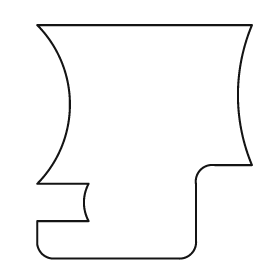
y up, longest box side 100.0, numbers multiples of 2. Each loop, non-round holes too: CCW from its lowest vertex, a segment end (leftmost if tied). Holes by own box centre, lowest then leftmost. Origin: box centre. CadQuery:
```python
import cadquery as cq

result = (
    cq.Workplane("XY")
    .moveTo(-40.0, -50.0)
    .lineTo(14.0, -50.0)
    .threePointArc((20.0, -48.0), (22.0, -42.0))
    .lineTo(22.0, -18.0)
    .threePointArc((24.0, -12.0), (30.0, -10.0))
    .lineTo(46.0, -10.0)
    .threePointArc((40.0, 20.0), (46.0, 50.0))
    .lineTo(-46.0, 50.0)
    .threePointArc((-32.0, 16.0), (-46.0, -18.0))
    .lineTo(-24.0, -18.0)
    .threePointArc((-26.0, -26.0), (-24.0, -34.0))
    .lineTo(-46.0, -34.0)
    .lineTo(-46.0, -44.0)
    .threePointArc((-44.0, -48.0), (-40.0, -50.0))
    .close()
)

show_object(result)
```